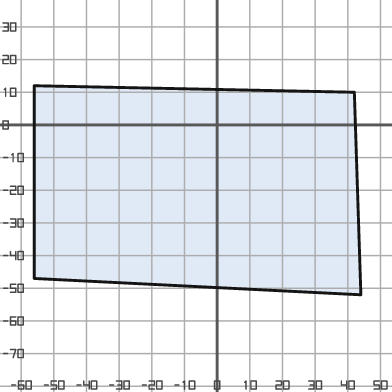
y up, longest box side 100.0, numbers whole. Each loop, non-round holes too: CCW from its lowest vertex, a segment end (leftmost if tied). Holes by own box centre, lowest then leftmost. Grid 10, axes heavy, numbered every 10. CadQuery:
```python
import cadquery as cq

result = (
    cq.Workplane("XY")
    .moveTo(44.0, -52.0)
    .lineTo(42.0, 10.0)
    .lineTo(-56.0, 12.0)
    .lineTo(-56.0, -47.0)
    .close()
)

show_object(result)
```